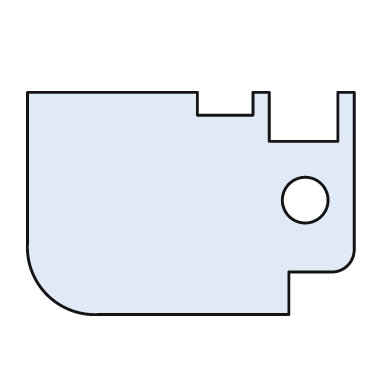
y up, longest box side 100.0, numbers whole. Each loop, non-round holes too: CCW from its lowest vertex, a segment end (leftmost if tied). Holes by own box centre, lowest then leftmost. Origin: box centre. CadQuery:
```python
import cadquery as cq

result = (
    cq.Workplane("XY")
    .moveTo(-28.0, -34.0)
    .lineTo(30.0, -34.0)
    .lineTo(30.0, -21.0)
    .lineTo(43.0, -21.0)
    .threePointArc((48.0, -19.0), (50.0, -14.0))
    .lineTo(50.0, 34.0)
    .lineTo(45.0, 34.0)
    .lineTo(45.0, 19.0)
    .lineTo(24.0, 19.0)
    .lineTo(24.0, 34.0)
    .lineTo(19.0, 34.0)
    .lineTo(19.0, 27.0)
    .lineTo(2.0, 27.0)
    .lineTo(2.0, 34.0)
    .lineTo(-50.0, 34.0)
    .lineTo(-50.0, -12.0)
    .threePointArc((-44.0, -28.0), (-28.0, -34.0))
    .close()
    .moveTo(35.0, 1.0)
    .circle(7.0)
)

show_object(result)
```